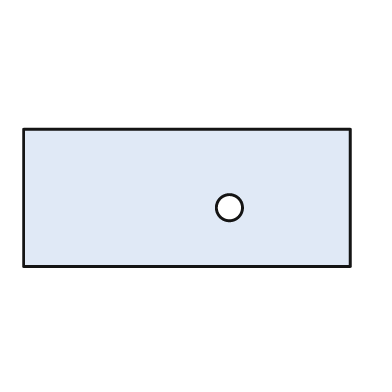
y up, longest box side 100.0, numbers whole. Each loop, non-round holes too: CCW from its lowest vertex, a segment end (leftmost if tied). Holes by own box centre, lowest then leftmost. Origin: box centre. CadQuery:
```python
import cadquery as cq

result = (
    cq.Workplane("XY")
    .moveTo(-50.0, -21.0)
    .lineTo(50.0, -21.0)
    .lineTo(50.0, 21.0)
    .lineTo(-50.0, 21.0)
    .close()
    .moveTo(13.0, -3.0)
    .circle(4.0)
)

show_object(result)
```